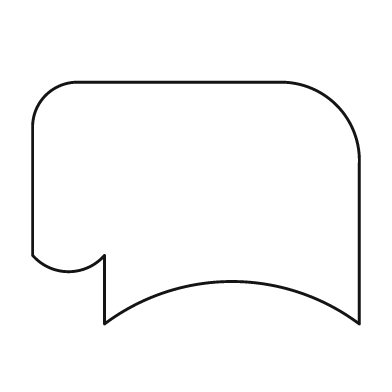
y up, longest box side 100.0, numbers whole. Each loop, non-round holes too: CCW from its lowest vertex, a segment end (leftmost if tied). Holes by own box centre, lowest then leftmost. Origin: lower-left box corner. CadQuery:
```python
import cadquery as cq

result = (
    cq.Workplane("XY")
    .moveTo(22.0, 0.0)
    .threePointArc((61.0, 13.0), (100.0, 0.0))
    .lineTo(100.0, 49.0)
    .threePointArc((93.0, 67.0), (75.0, 74.0))
    .lineTo(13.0, 74.0)
    .threePointArc((4.0, 70.0), (0.0, 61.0))
    .lineTo(0.0, 21.0)
    .threePointArc((11.0, 16.0), (22.0, 21.0))
    .close()
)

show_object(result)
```